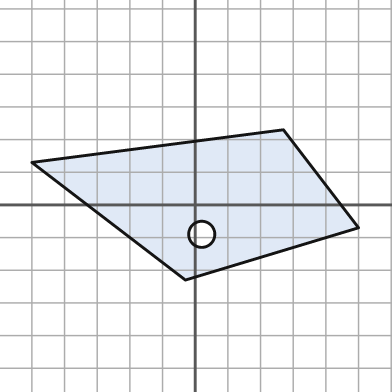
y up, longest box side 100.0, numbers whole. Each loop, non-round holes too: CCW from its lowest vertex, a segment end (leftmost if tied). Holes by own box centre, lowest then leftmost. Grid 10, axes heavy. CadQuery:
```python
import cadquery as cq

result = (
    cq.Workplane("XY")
    .moveTo(-3.0, -23.0)
    .lineTo(50.0, -7.0)
    .lineTo(27.0, 23.0)
    .lineTo(-50.0, 13.0)
    .close()
    .moveTo(2.0, -9.0)
    .circle(4.0)
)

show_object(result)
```